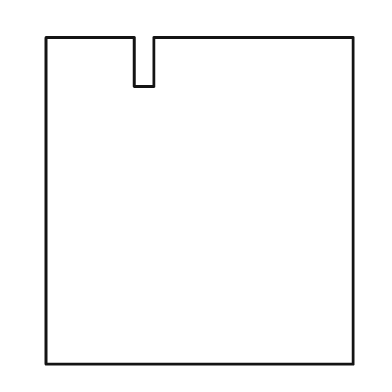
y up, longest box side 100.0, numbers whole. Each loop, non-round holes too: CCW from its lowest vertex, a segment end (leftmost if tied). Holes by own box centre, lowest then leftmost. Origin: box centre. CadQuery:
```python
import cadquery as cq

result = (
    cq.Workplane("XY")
    .moveTo(-47.0, -50.0)
    .lineTo(47.0, -50.0)
    .lineTo(47.0, 50.0)
    .lineTo(-14.0, 50.0)
    .lineTo(-14.0, 35.0)
    .lineTo(-20.0, 35.0)
    .lineTo(-20.0, 50.0)
    .lineTo(-47.0, 50.0)
    .close()
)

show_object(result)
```